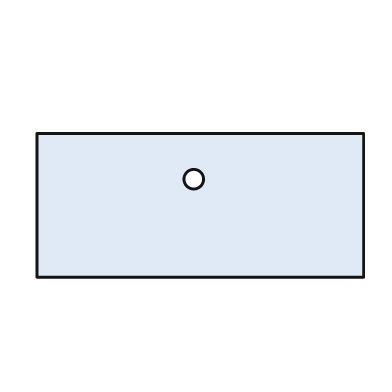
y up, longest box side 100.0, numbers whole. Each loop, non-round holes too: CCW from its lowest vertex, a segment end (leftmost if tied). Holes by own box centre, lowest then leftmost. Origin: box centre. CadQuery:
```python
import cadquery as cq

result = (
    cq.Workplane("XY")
    .moveTo(-50.0, -22.0)
    .lineTo(50.0, -22.0)
    .lineTo(50.0, 22.0)
    .lineTo(-50.0, 22.0)
    .close()
    .moveTo(-2.0, 8.0)
    .circle(3.0)
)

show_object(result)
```